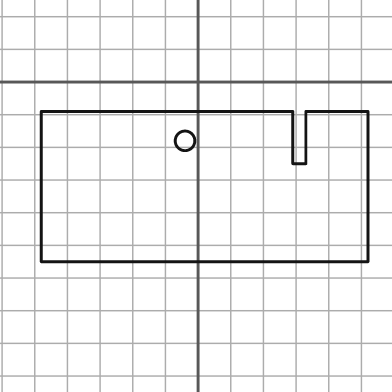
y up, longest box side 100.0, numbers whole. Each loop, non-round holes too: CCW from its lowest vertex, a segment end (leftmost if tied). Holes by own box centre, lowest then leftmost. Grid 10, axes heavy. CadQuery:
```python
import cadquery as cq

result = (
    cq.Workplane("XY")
    .moveTo(-48.0, -55.0)
    .lineTo(52.0, -55.0)
    .lineTo(52.0, -9.0)
    .lineTo(33.0, -9.0)
    .lineTo(33.0, -25.0)
    .lineTo(29.0, -25.0)
    .lineTo(29.0, -9.0)
    .lineTo(-48.0, -9.0)
    .close()
    .moveTo(-4.0, -18.0)
    .circle(3.0)
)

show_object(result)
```